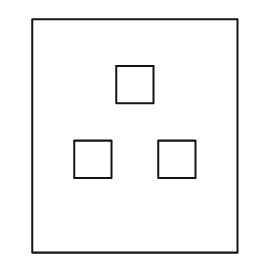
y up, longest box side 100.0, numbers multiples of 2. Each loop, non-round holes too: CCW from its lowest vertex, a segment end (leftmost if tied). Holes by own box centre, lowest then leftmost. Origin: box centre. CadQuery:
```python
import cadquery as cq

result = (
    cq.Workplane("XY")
    .moveTo(-44.0, -50.0)
    .lineTo(44.0, -50.0)
    .lineTo(44.0, 50.0)
    .lineTo(-44.0, 50.0)
    .close()
    .moveTo(-26.0, -18.0)
    .lineTo(-10.0, -18.0)
    .lineTo(-10.0, -2.0)
    .lineTo(-26.0, -2.0)
    .close()
    .moveTo(10.0, -18.0)
    .lineTo(26.0, -18.0)
    .lineTo(26.0, -2.0)
    .lineTo(10.0, -2.0)
    .close()
    .moveTo(-8.0, 14.0)
    .lineTo(8.0, 14.0)
    .lineTo(8.0, 30.0)
    .lineTo(-8.0, 30.0)
    .close()
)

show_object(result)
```